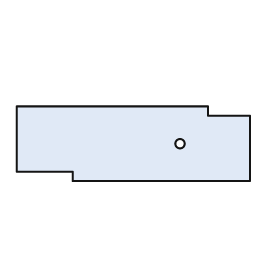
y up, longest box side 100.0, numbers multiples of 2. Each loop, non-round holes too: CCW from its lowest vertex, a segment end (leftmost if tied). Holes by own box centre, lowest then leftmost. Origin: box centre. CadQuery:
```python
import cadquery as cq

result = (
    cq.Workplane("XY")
    .moveTo(-26.0, -16.0)
    .lineTo(50.0, -16.0)
    .lineTo(50.0, 12.0)
    .lineTo(32.0, 12.0)
    .lineTo(32.0, 16.0)
    .lineTo(-50.0, 16.0)
    .lineTo(-50.0, -12.0)
    .lineTo(-26.0, -12.0)
    .close()
    .moveTo(20.0, 0.0)
    .circle(2.0)
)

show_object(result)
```